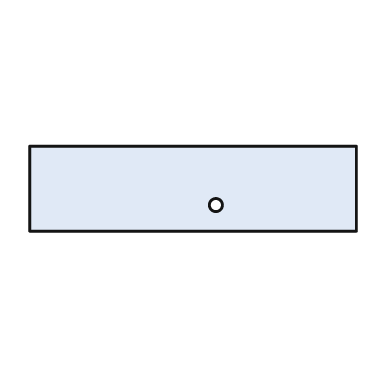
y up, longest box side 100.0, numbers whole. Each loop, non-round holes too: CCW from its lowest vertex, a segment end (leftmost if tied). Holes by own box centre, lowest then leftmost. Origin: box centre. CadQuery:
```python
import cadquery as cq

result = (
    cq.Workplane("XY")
    .moveTo(-50.0, -13.0)
    .lineTo(50.0, -13.0)
    .lineTo(50.0, 13.0)
    .lineTo(-50.0, 13.0)
    .close()
    .moveTo(7.0, -5.0)
    .circle(2.0)
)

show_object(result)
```